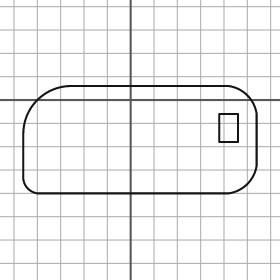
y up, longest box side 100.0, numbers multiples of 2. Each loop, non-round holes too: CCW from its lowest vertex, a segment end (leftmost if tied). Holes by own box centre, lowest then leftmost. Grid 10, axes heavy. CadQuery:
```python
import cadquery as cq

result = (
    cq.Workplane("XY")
    .moveTo(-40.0, -40.0)
    .lineTo(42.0, -40.0)
    .threePointArc((50.0, -36.0), (54.0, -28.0))
    .lineTo(54.0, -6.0)
    .threePointArc((50.0, 2.0), (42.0, 6.0))
    .lineTo(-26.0, 6.0)
    .threePointArc((-40.0, 0.0), (-46.0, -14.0))
    .lineTo(-46.0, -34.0)
    .threePointArc((-44.0, -38.0), (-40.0, -40.0))
    .close()
    .moveTo(38.0, -18.0)
    .lineTo(46.0, -18.0)
    .lineTo(46.0, -6.0)
    .lineTo(38.0, -6.0)
    .close()
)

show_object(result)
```